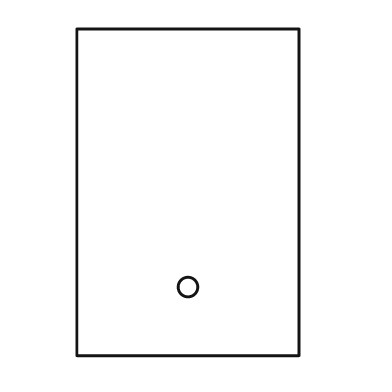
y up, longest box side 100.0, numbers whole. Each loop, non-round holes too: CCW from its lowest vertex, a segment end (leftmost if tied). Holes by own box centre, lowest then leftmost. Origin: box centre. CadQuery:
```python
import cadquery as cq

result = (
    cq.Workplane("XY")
    .moveTo(-34.0, -50.0)
    .lineTo(34.0, -50.0)
    .lineTo(34.0, 50.0)
    .lineTo(-34.0, 50.0)
    .close()
    .moveTo(0.0, -29.0)
    .circle(3.0)
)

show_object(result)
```